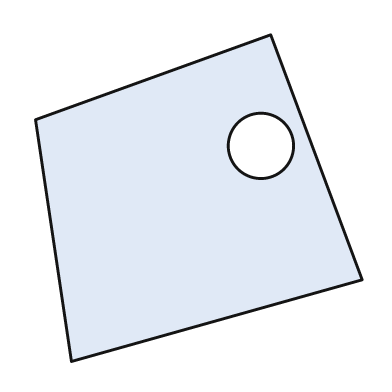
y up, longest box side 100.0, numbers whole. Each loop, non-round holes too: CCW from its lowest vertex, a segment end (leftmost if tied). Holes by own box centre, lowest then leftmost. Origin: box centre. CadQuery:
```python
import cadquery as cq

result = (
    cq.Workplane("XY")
    .moveTo(-39.0, -50.0)
    .lineTo(50.0, -25.0)
    .lineTo(22.0, 50.0)
    .lineTo(-50.0, 24.0)
    .close()
    .moveTo(19.0, 16.0)
    .circle(10.0)
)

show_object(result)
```